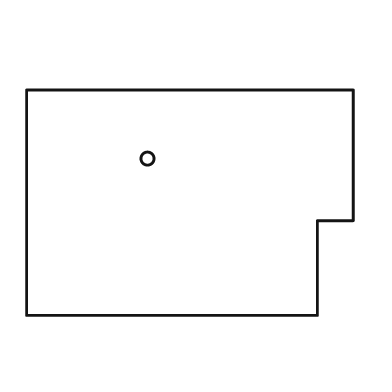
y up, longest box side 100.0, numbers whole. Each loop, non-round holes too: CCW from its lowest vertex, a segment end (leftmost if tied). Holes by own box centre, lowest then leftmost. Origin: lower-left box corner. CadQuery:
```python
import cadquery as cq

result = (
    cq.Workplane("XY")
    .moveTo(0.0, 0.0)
    .lineTo(89.0, 0.0)
    .lineTo(89.0, 29.0)
    .lineTo(100.0, 29.0)
    .lineTo(100.0, 69.0)
    .lineTo(0.0, 69.0)
    .close()
    .moveTo(37.0, 48.0)
    .circle(2.0)
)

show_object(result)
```